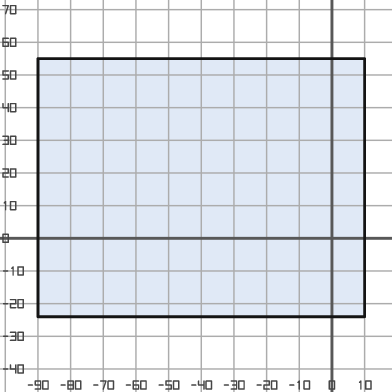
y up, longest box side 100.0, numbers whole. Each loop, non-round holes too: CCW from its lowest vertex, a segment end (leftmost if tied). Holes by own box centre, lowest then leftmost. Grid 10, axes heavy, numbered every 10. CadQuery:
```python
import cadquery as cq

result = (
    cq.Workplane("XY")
    .moveTo(-90.0, -24.0)
    .lineTo(10.0, -24.0)
    .lineTo(10.0, 55.0)
    .lineTo(-90.0, 55.0)
    .close()
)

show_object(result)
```